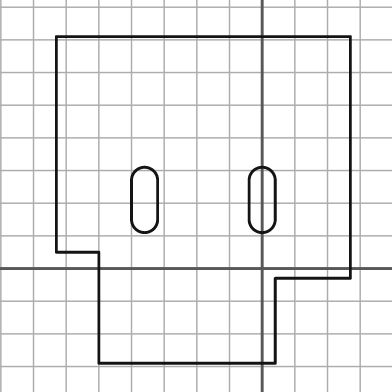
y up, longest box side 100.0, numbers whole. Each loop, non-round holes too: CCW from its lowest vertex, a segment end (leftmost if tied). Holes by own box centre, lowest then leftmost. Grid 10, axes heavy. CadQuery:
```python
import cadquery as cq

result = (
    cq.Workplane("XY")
    .moveTo(-50.0, -29.0)
    .lineTo(4.0, -29.0)
    .lineTo(4.0, -3.0)
    .lineTo(27.0, -3.0)
    .lineTo(27.0, 71.0)
    .lineTo(-63.0, 71.0)
    .lineTo(-63.0, 5.0)
    .lineTo(-50.0, 5.0)
    .close()
    .moveTo(-40.0, 15.0)
    .threePointArc((-36.0, 11.0), (-32.0, 15.0))
    .lineTo(-32.0, 27.0)
    .threePointArc((-36.0, 31.0), (-40.0, 27.0))
    .close()
    .moveTo(-4.0, 15.0)
    .threePointArc((0.0, 11.0), (4.0, 15.0))
    .lineTo(4.0, 27.0)
    .threePointArc((0.0, 31.0), (-4.0, 27.0))
    .close()
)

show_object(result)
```